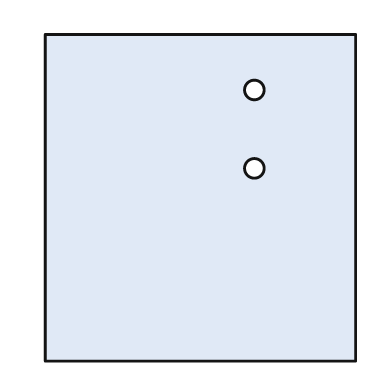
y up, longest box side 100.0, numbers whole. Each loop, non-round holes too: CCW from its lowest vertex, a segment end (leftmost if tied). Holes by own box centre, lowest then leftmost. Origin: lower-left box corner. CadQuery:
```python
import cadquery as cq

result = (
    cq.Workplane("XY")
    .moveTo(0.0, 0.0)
    .lineTo(95.0, 0.0)
    .lineTo(95.0, 100.0)
    .lineTo(0.0, 100.0)
    .close()
    .moveTo(64.0, 59.0)
    .circle(3.0)
    .moveTo(64.0, 83.0)
    .circle(3.0)
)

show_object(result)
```